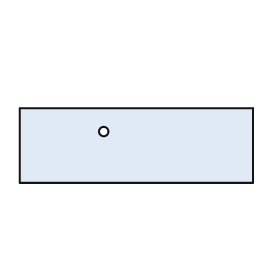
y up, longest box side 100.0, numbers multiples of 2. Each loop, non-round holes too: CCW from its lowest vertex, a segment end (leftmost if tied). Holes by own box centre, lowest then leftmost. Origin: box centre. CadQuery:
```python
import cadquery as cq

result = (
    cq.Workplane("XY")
    .moveTo(-50.0, -16.0)
    .lineTo(50.0, -16.0)
    .lineTo(50.0, 16.0)
    .lineTo(-50.0, 16.0)
    .close()
    .moveTo(-14.0, 6.0)
    .circle(2.0)
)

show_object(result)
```